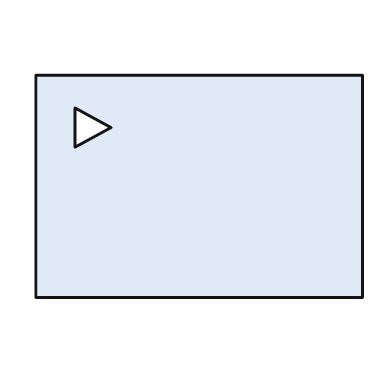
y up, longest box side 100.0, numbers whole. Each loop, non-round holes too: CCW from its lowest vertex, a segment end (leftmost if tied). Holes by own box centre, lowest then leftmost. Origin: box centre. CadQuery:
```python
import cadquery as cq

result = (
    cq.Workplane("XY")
    .moveTo(-50.0, -34.0)
    .lineTo(50.0, -34.0)
    .lineTo(50.0, 34.0)
    .lineTo(-50.0, 34.0)
    .close()
    .moveTo(-38.0, 12.0)
    .lineTo(-27.0, 18.0)
    .lineTo(-38.0, 24.0)
    .close()
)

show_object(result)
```